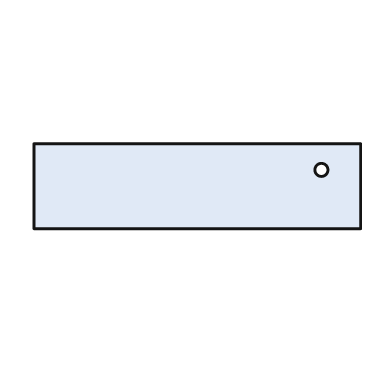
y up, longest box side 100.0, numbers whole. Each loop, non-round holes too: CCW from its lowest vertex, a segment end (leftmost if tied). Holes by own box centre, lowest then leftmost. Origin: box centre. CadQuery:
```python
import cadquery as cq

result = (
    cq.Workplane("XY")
    .moveTo(-50.0, -13.0)
    .lineTo(50.0, -13.0)
    .lineTo(50.0, 13.0)
    .lineTo(-50.0, 13.0)
    .close()
    .moveTo(38.0, 5.0)
    .circle(2.0)
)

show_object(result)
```